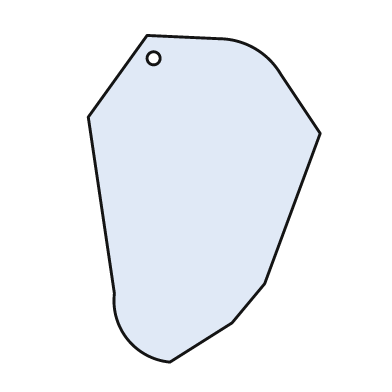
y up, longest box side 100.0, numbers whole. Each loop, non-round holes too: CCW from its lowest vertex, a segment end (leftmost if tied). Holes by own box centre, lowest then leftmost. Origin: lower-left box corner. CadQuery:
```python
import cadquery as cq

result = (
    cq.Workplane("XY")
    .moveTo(25.0, 0.0)
    .lineTo(44.0, 12.0)
    .lineTo(54.0, 24.0)
    .lineTo(71.0, 70.0)
    .lineTo(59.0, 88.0)
    .threePointArc((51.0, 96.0), (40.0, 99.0))
    .lineTo(18.0, 100.0)
    .lineTo(0.0, 75.0)
    .lineTo(8.0, 21.0)
    .threePointArc((12.0, 7.0), (25.0, 0.0))
    .close()
    .moveTo(20.0, 93.0)
    .circle(2.0)
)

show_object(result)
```